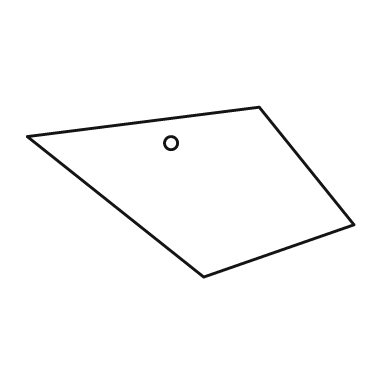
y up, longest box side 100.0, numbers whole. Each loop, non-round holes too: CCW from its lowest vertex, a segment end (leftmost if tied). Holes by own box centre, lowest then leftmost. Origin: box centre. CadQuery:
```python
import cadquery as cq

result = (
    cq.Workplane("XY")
    .moveTo(4.0, -26.0)
    .lineTo(50.0, -10.0)
    .lineTo(21.0, 26.0)
    .lineTo(-50.0, 17.0)
    .close()
    .moveTo(-6.0, 15.0)
    .circle(2.0)
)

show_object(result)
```